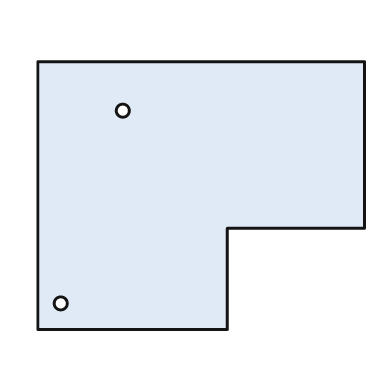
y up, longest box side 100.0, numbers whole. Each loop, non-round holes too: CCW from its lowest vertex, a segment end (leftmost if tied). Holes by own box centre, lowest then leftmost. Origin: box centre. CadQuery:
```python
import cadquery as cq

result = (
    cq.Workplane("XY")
    .moveTo(-50.0, -41.0)
    .lineTo(8.0, -41.0)
    .lineTo(8.0, -10.0)
    .lineTo(50.0, -10.0)
    .lineTo(50.0, 41.0)
    .lineTo(-50.0, 41.0)
    .close()
    .moveTo(-43.0, -33.0)
    .circle(2.0)
    .moveTo(-24.0, 26.0)
    .circle(2.0)
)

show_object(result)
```